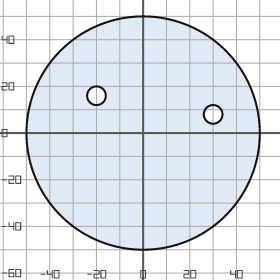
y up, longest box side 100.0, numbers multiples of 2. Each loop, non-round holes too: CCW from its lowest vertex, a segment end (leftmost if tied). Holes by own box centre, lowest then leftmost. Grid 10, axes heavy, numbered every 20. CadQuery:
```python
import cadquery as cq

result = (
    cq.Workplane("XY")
    .moveTo(0.0, 0.0)
    .circle(50.0)
    .moveTo(30.0, 8.0)
    .circle(4.0)
    .moveTo(-20.0, 16.0)
    .circle(4.0)
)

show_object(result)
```